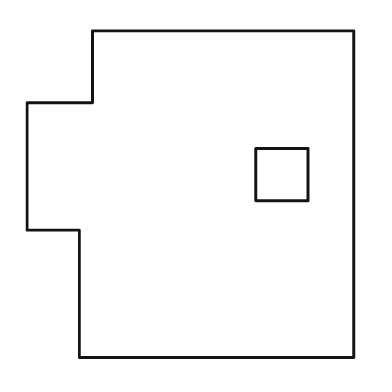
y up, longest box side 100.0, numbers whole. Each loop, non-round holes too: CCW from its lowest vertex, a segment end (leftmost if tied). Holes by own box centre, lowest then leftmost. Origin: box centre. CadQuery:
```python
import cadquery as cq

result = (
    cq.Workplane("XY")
    .moveTo(-34.0, -50.0)
    .lineTo(50.0, -50.0)
    .lineTo(50.0, 50.0)
    .lineTo(-30.0, 50.0)
    .lineTo(-30.0, 28.0)
    .lineTo(-50.0, 28.0)
    .lineTo(-50.0, -11.0)
    .lineTo(-34.0, -11.0)
    .close()
    .moveTo(20.0, -2.0)
    .lineTo(36.0, -2.0)
    .lineTo(36.0, 14.0)
    .lineTo(20.0, 14.0)
    .close()
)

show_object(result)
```